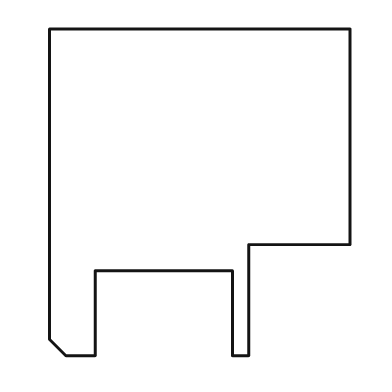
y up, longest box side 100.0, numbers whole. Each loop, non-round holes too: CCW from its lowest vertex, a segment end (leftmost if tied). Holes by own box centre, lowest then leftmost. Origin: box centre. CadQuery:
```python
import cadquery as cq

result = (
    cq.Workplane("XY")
    .moveTo(-41.0, -50.0)
    .lineTo(-32.0, -50.0)
    .lineTo(-32.0, -24.0)
    .lineTo(10.0, -24.0)
    .lineTo(10.0, -50.0)
    .lineTo(15.0, -50.0)
    .lineTo(15.0, -16.0)
    .lineTo(46.0, -16.0)
    .lineTo(46.0, 50.0)
    .lineTo(-46.0, 50.0)
    .lineTo(-46.0, -45.0)
    .close()
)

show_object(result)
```